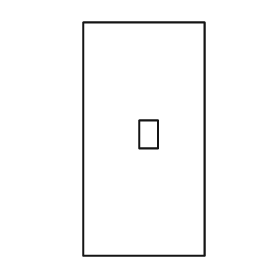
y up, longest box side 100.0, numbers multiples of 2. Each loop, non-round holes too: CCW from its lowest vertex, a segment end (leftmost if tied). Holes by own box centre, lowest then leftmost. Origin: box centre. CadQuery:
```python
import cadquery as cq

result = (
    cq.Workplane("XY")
    .moveTo(-26.0, -50.0)
    .lineTo(26.0, -50.0)
    .lineTo(26.0, 50.0)
    .lineTo(-26.0, 50.0)
    .close()
    .moveTo(-2.0, -4.0)
    .lineTo(6.0, -4.0)
    .lineTo(6.0, 8.0)
    .lineTo(-2.0, 8.0)
    .close()
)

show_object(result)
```